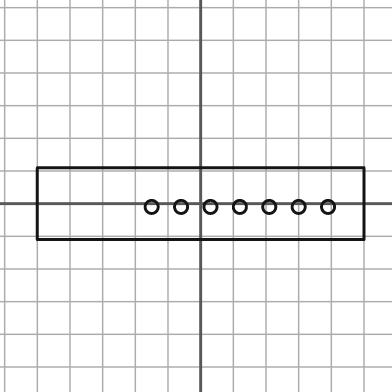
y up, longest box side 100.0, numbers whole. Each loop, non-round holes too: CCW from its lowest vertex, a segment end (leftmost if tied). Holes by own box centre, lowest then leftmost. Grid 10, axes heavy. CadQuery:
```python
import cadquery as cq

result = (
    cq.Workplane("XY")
    .moveTo(-50.0, -11.0)
    .lineTo(50.0, -11.0)
    .lineTo(50.0, 11.0)
    .lineTo(-50.0, 11.0)
    .close()
    .moveTo(-15.0, -1.0)
    .circle(2.0)
    .moveTo(-6.0, -1.0)
    .circle(2.0)
    .moveTo(3.0, -1.0)
    .circle(2.0)
    .moveTo(12.0, -1.0)
    .circle(2.0)
    .moveTo(21.0, -1.0)
    .circle(2.0)
    .moveTo(30.0, -1.0)
    .circle(2.0)
    .moveTo(39.0, -1.0)
    .circle(2.0)
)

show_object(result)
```